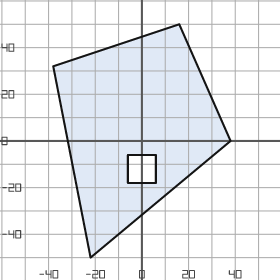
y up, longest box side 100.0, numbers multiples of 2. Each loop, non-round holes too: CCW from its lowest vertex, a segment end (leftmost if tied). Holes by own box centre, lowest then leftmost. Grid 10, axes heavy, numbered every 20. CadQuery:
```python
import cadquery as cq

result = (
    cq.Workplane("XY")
    .moveTo(-22.0, -50.0)
    .lineTo(38.0, 0.0)
    .lineTo(16.0, 50.0)
    .lineTo(-38.0, 32.0)
    .close()
    .moveTo(-6.0, -18.0)
    .lineTo(6.0, -18.0)
    .lineTo(6.0, -6.0)
    .lineTo(-6.0, -6.0)
    .close()
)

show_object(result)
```